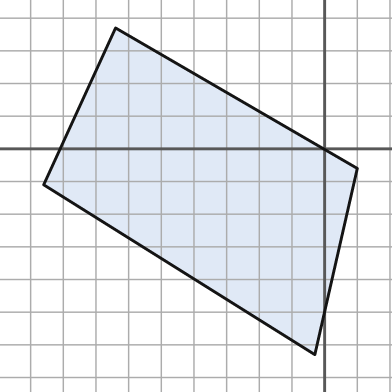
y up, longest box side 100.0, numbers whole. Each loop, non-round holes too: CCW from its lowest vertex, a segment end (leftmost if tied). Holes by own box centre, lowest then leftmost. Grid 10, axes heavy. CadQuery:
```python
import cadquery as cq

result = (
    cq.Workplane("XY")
    .moveTo(-3.0, -63.0)
    .lineTo(10.0, -6.0)
    .lineTo(-64.0, 37.0)
    .lineTo(-86.0, -11.0)
    .close()
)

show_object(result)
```